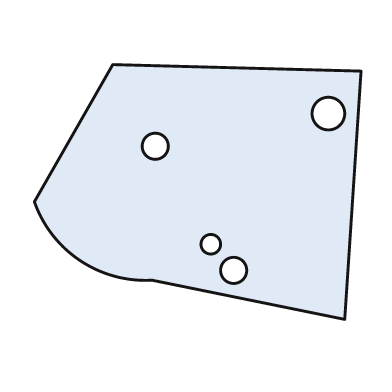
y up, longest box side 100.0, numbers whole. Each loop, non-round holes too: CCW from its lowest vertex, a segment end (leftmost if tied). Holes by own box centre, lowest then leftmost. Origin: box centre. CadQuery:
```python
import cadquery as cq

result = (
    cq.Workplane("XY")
    .moveTo(45.0, -39.0)
    .lineTo(50.0, 37.0)
    .lineTo(-26.0, 39.0)
    .lineTo(-50.0, -3.0)
    .threePointArc((-36.0, -21.0), (-14.0, -27.0))
    .close()
    .moveTo(11.0, -24.0)
    .circle(4.0)
    .moveTo(4.0, -16.0)
    .circle(3.0)
    .moveTo(-13.0, 14.0)
    .circle(4.0)
    .moveTo(40.0, 24.0)
    .circle(5.0)
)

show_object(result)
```